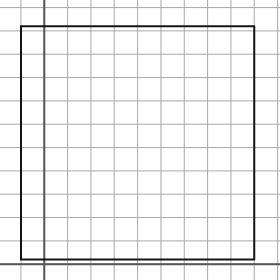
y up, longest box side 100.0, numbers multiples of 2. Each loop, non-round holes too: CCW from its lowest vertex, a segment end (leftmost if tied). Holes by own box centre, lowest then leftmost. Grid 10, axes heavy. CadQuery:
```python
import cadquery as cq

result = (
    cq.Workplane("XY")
    .moveTo(-10.0, 2.0)
    .lineTo(90.0, 2.0)
    .lineTo(90.0, 102.0)
    .lineTo(-10.0, 102.0)
    .close()
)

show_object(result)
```